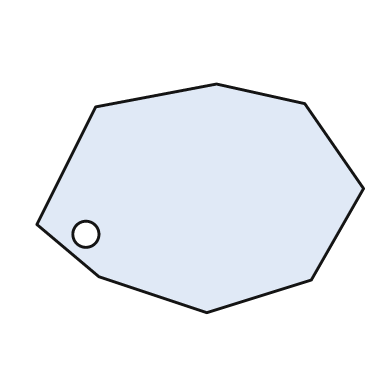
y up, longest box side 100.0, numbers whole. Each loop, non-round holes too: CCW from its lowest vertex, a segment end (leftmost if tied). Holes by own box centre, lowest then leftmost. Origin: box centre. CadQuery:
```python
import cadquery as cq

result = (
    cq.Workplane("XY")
    .moveTo(2.0, -35.0)
    .lineTo(34.0, -25.0)
    .lineTo(50.0, 3.0)
    .lineTo(32.0, 29.0)
    .lineTo(5.0, 35.0)
    .lineTo(-32.0, 28.0)
    .lineTo(-50.0, -8.0)
    .lineTo(-31.0, -24.0)
    .close()
    .moveTo(-35.0, -11.0)
    .circle(4.0)
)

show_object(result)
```